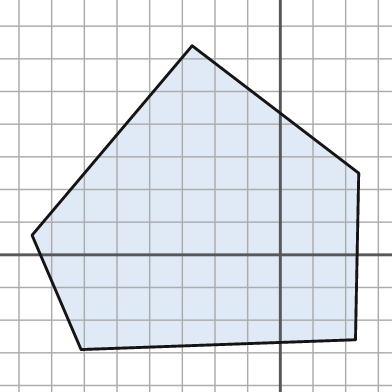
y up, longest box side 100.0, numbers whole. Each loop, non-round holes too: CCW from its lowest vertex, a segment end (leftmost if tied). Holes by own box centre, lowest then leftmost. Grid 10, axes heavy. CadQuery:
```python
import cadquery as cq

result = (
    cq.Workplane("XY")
    .moveTo(-61.0, -29.0)
    .lineTo(23.0, -26.0)
    .lineTo(24.0, 25.0)
    .lineTo(-27.0, 64.0)
    .lineTo(-76.0, 6.0)
    .close()
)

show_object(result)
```